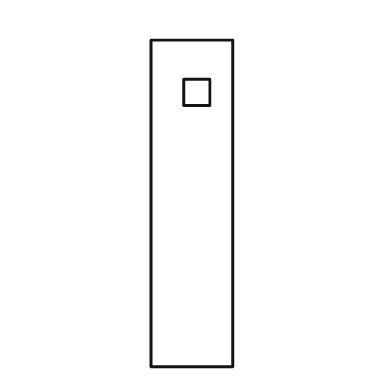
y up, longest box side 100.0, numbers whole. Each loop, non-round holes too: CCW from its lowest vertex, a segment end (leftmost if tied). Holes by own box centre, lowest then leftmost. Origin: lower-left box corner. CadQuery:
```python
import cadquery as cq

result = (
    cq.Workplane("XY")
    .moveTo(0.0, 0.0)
    .lineTo(25.0, 0.0)
    .lineTo(25.0, 100.0)
    .lineTo(0.0, 100.0)
    .close()
    .moveTo(10.0, 80.0)
    .lineTo(18.0, 80.0)
    .lineTo(18.0, 88.0)
    .lineTo(10.0, 88.0)
    .close()
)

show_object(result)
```